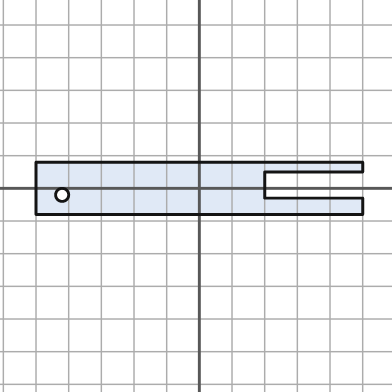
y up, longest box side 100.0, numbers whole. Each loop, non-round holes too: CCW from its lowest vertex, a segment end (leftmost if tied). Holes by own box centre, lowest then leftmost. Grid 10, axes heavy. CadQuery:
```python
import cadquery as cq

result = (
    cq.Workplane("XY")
    .moveTo(-50.0, -8.0)
    .lineTo(50.0, -8.0)
    .lineTo(50.0, -3.0)
    .lineTo(20.0, -3.0)
    .lineTo(20.0, 5.0)
    .lineTo(50.0, 5.0)
    .lineTo(50.0, 8.0)
    .lineTo(-50.0, 8.0)
    .close()
    .moveTo(-42.0, -2.0)
    .circle(2.0)
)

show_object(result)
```